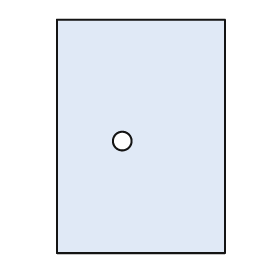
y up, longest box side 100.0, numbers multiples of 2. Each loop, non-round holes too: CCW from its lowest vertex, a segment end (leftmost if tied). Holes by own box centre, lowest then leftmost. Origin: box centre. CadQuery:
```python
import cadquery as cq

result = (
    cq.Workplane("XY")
    .moveTo(-36.0, -50.0)
    .lineTo(36.0, -50.0)
    .lineTo(36.0, 50.0)
    .lineTo(-36.0, 50.0)
    .close()
    .moveTo(-8.0, -2.0)
    .circle(4.0)
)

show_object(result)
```